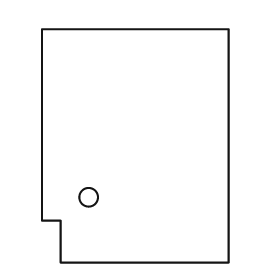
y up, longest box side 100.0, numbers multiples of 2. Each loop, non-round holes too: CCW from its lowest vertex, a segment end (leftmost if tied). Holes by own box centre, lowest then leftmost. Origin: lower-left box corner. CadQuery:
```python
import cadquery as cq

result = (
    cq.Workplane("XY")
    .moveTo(8.0, 0.0)
    .lineTo(80.0, 0.0)
    .lineTo(80.0, 100.0)
    .lineTo(0.0, 100.0)
    .lineTo(0.0, 18.0)
    .lineTo(8.0, 18.0)
    .close()
    .moveTo(20.0, 28.0)
    .circle(4.0)
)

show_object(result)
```